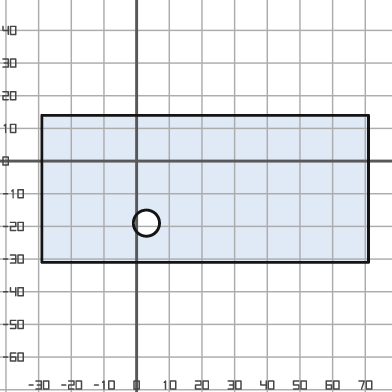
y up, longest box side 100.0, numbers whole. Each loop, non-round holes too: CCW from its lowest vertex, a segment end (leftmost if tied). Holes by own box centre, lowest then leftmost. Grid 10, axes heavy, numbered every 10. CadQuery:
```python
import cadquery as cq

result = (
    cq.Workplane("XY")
    .moveTo(-29.0, -31.0)
    .lineTo(71.0, -31.0)
    .lineTo(71.0, 14.0)
    .lineTo(-29.0, 14.0)
    .close()
    .moveTo(3.0, -19.0)
    .circle(4.0)
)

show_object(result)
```